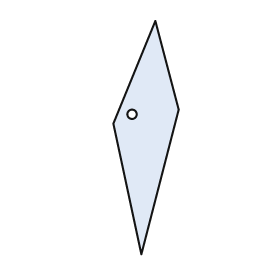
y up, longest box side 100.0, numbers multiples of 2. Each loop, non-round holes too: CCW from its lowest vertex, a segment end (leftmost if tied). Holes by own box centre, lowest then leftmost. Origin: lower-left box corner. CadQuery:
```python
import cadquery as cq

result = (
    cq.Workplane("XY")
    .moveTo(12.0, 0.0)
    .lineTo(28.0, 62.0)
    .lineTo(18.0, 100.0)
    .lineTo(0.0, 56.0)
    .close()
    .moveTo(8.0, 60.0)
    .circle(2.0)
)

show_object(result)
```